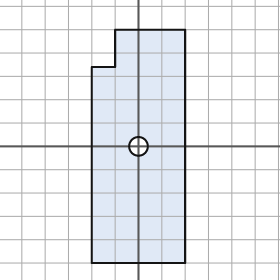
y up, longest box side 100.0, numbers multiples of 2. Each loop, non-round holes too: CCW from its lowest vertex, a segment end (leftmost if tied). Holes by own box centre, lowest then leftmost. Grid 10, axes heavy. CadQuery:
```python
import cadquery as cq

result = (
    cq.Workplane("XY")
    .moveTo(-20.0, -50.0)
    .lineTo(20.0, -50.0)
    .lineTo(20.0, 50.0)
    .lineTo(-10.0, 50.0)
    .lineTo(-10.0, 34.0)
    .lineTo(-20.0, 34.0)
    .close()
    .moveTo(0.0, 0.0)
    .circle(4.0)
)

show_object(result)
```